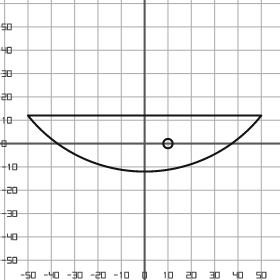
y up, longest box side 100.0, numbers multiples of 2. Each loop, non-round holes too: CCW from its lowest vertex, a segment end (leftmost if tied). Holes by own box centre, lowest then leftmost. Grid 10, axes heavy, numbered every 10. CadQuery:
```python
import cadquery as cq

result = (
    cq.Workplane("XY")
    .moveTo(-50.0, 12.0)
    .threePointArc((0.0, -12.0), (50.0, 12.0))
    .close()
    .moveTo(10.0, 0.0)
    .circle(2.0)
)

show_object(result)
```